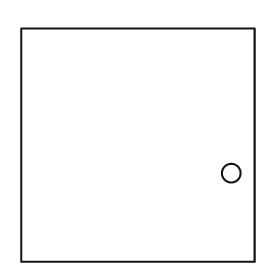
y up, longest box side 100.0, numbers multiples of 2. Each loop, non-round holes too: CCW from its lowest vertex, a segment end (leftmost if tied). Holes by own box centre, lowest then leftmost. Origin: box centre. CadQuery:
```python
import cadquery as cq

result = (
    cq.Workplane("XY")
    .moveTo(-50.0, -50.0)
    .lineTo(50.0, -50.0)
    .lineTo(50.0, 50.0)
    .lineTo(-50.0, 50.0)
    .close()
    .moveTo(40.0, -12.0)
    .circle(4.0)
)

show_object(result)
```